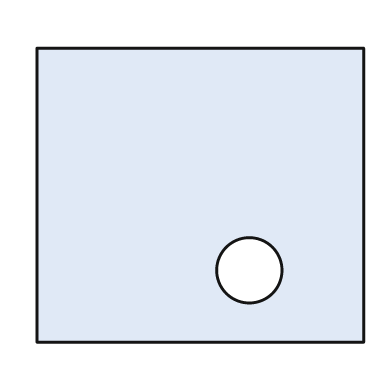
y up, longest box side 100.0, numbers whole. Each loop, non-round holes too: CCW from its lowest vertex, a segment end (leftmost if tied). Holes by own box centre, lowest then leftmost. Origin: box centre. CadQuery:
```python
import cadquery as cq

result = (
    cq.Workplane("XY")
    .moveTo(-50.0, -45.0)
    .lineTo(50.0, -45.0)
    .lineTo(50.0, 45.0)
    .lineTo(-50.0, 45.0)
    .close()
    .moveTo(15.0, -23.0)
    .circle(10.0)
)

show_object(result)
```